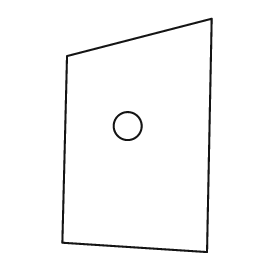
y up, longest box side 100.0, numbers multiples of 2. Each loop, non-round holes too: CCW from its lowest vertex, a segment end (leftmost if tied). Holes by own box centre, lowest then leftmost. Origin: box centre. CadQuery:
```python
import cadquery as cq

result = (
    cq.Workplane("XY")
    .moveTo(30.0, -50.0)
    .lineTo(32.0, 50.0)
    .lineTo(-30.0, 34.0)
    .lineTo(-32.0, -46.0)
    .close()
    .moveTo(-4.0, 4.0)
    .circle(6.0)
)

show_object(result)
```